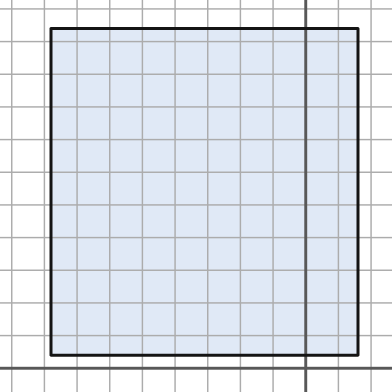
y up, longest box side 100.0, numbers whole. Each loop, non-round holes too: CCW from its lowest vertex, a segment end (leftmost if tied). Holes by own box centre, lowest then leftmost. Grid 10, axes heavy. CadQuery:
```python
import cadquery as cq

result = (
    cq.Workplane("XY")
    .moveTo(-78.0, 4.0)
    .lineTo(16.0, 4.0)
    .lineTo(16.0, 104.0)
    .lineTo(-78.0, 104.0)
    .close()
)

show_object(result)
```